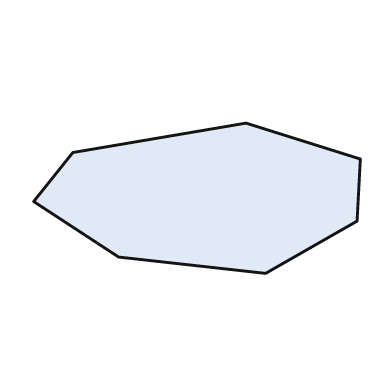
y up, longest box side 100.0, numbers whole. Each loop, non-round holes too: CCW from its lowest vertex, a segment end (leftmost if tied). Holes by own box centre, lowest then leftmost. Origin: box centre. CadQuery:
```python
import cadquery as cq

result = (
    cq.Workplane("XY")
    .moveTo(21.0, -23.0)
    .lineTo(49.0, -7.0)
    .lineTo(50.0, 12.0)
    .lineTo(15.0, 23.0)
    .lineTo(-38.0, 14.0)
    .lineTo(-50.0, -1.0)
    .lineTo(-24.0, -18.0)
    .close()
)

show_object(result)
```